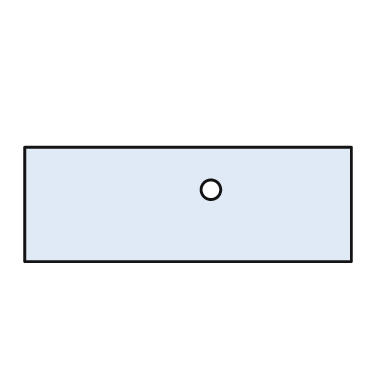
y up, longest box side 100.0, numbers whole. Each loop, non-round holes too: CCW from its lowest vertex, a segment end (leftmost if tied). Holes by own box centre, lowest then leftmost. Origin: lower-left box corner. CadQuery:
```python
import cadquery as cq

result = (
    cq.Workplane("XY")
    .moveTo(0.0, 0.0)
    .lineTo(100.0, 0.0)
    .lineTo(100.0, 35.0)
    .lineTo(0.0, 35.0)
    .close()
    .moveTo(57.0, 22.0)
    .circle(3.0)
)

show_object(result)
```